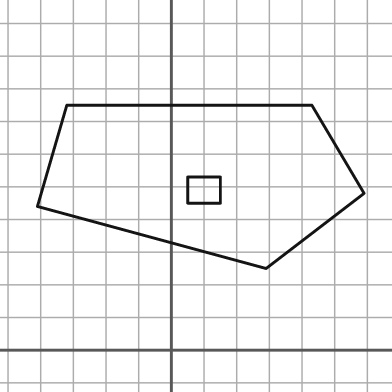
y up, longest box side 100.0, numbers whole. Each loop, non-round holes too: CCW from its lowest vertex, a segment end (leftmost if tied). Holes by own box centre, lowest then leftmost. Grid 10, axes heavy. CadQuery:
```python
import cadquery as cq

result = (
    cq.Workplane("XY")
    .moveTo(29.0, 25.0)
    .lineTo(59.0, 48.0)
    .lineTo(43.0, 75.0)
    .lineTo(-32.0, 75.0)
    .lineTo(-41.0, 44.0)
    .close()
    .moveTo(5.0, 45.0)
    .lineTo(15.0, 45.0)
    .lineTo(15.0, 53.0)
    .lineTo(5.0, 53.0)
    .close()
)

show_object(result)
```